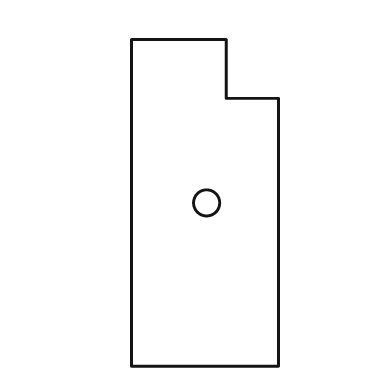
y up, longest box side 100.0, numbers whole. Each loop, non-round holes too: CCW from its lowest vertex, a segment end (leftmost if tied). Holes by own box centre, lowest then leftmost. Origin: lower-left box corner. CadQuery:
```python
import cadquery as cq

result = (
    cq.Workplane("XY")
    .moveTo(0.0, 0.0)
    .lineTo(45.0, 0.0)
    .lineTo(45.0, 82.0)
    .lineTo(29.0, 82.0)
    .lineTo(29.0, 100.0)
    .lineTo(0.0, 100.0)
    .close()
    .moveTo(23.0, 50.0)
    .circle(4.0)
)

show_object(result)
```